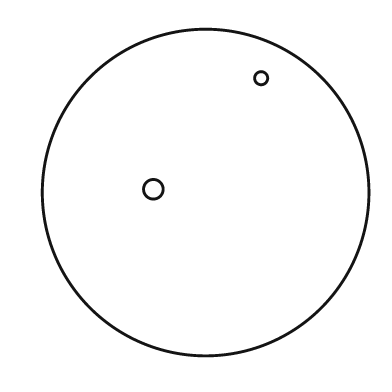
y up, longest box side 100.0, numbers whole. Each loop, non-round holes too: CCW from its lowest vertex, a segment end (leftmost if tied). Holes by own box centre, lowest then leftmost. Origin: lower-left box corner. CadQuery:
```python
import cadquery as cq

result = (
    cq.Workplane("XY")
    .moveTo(50.0, 50.0)
    .circle(50.0)
    .moveTo(34.0, 51.0)
    .circle(3.0)
    .moveTo(67.0, 85.0)
    .circle(2.0)
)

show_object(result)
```